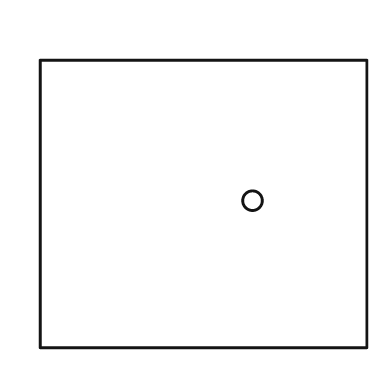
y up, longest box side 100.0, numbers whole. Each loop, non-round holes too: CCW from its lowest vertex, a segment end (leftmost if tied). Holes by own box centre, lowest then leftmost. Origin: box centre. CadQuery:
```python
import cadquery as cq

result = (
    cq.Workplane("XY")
    .moveTo(-50.0, -44.0)
    .lineTo(50.0, -44.0)
    .lineTo(50.0, 44.0)
    .lineTo(-50.0, 44.0)
    .close()
    .moveTo(15.0, 1.0)
    .circle(3.0)
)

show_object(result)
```